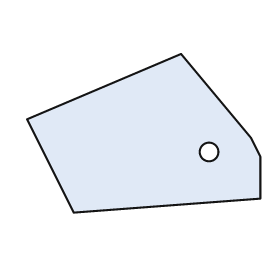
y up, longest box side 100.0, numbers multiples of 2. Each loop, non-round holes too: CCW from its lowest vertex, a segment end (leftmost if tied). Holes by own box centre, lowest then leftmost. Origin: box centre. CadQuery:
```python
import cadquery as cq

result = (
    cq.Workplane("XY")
    .moveTo(-30.0, -34.0)
    .lineTo(50.0, -28.0)
    .lineTo(50.0, -10.0)
    .lineTo(46.0, -2.0)
    .lineTo(16.0, 34.0)
    .lineTo(-50.0, 6.0)
    .close()
    .moveTo(28.0, -8.0)
    .circle(4.0)
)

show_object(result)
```